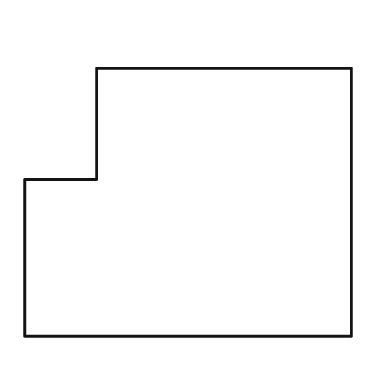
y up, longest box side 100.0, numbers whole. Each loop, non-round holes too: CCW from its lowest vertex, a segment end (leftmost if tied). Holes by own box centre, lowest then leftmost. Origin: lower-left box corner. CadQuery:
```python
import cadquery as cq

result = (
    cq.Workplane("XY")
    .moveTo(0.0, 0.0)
    .lineTo(100.0, 0.0)
    .lineTo(100.0, 82.0)
    .lineTo(22.0, 82.0)
    .lineTo(22.0, 48.0)
    .lineTo(0.0, 48.0)
    .close()
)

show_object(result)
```